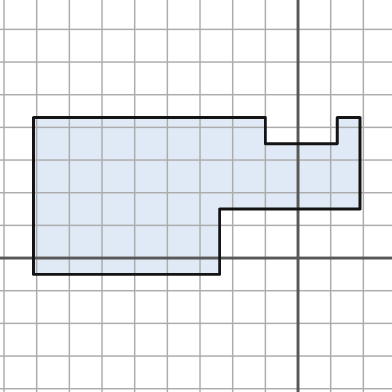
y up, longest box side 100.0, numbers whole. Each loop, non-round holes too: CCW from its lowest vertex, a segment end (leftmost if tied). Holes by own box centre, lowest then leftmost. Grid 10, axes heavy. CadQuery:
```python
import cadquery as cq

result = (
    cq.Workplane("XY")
    .moveTo(-81.0, -5.0)
    .lineTo(-24.0, -5.0)
    .lineTo(-24.0, 15.0)
    .lineTo(19.0, 15.0)
    .lineTo(19.0, 43.0)
    .lineTo(12.0, 43.0)
    .lineTo(12.0, 35.0)
    .lineTo(-10.0, 35.0)
    .lineTo(-10.0, 43.0)
    .lineTo(-81.0, 43.0)
    .close()
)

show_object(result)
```